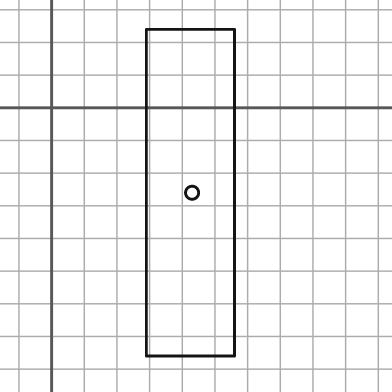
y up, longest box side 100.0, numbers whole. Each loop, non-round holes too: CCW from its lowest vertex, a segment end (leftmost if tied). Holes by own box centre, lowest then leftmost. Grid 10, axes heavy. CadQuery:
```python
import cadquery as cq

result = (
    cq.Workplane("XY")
    .moveTo(29.0, -76.0)
    .lineTo(56.0, -76.0)
    .lineTo(56.0, 24.0)
    .lineTo(29.0, 24.0)
    .close()
    .moveTo(43.0, -26.0)
    .circle(2.0)
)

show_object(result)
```